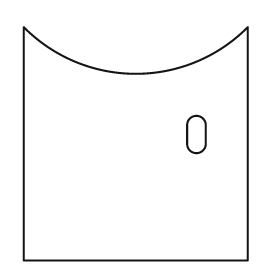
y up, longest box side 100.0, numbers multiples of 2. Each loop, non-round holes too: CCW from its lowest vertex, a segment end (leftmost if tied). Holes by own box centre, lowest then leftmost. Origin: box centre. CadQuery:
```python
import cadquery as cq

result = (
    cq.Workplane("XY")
    .moveTo(-48.0, -50.0)
    .lineTo(48.0, -50.0)
    .lineTo(48.0, 50.0)
    .threePointArc((0.0, 30.0), (-48.0, 50.0))
    .close()
    .moveTo(22.0, 0.0)
    .threePointArc((26.0, -4.0), (30.0, 0.0))
    .lineTo(30.0, 8.0)
    .threePointArc((26.0, 12.0), (22.0, 8.0))
    .close()
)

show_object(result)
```